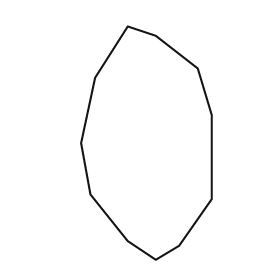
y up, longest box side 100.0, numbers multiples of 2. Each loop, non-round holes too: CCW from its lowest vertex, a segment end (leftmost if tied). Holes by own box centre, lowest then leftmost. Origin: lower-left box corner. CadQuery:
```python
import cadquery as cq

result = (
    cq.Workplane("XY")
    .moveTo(32.0, 0.0)
    .lineTo(42.0, 6.0)
    .lineTo(56.0, 26.0)
    .lineTo(56.0, 62.0)
    .lineTo(50.0, 82.0)
    .lineTo(32.0, 96.0)
    .lineTo(20.0, 100.0)
    .lineTo(6.0, 78.0)
    .lineTo(0.0, 50.0)
    .lineTo(4.0, 28.0)
    .lineTo(20.0, 8.0)
    .close()
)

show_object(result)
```